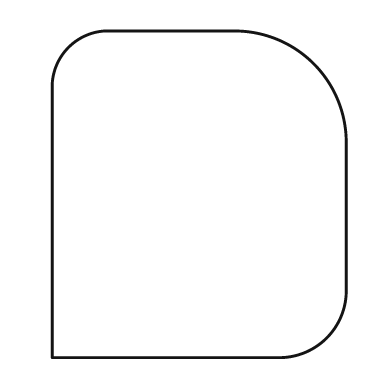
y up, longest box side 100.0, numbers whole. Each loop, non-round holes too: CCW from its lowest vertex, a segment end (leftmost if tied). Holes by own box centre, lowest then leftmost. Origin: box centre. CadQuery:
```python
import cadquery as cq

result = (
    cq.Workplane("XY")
    .moveTo(-45.0, -50.0)
    .lineTo(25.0, -50.0)
    .threePointArc((39.0, -44.0), (45.0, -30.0))
    .lineTo(45.0, 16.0)
    .threePointArc((35.0, 40.0), (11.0, 50.0))
    .lineTo(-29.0, 50.0)
    .threePointArc((-40.0, 45.0), (-45.0, 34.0))
    .close()
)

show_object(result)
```